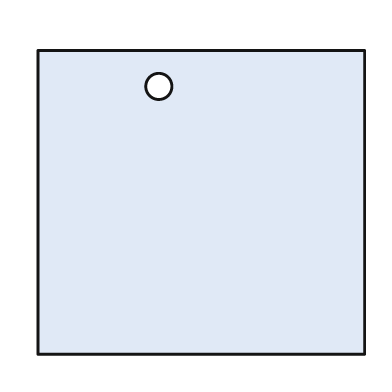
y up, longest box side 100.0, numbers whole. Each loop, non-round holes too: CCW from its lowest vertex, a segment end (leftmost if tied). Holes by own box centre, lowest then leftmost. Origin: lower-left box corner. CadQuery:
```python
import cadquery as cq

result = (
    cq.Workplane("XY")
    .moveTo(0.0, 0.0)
    .lineTo(100.0, 0.0)
    .lineTo(100.0, 93.0)
    .lineTo(0.0, 93.0)
    .close()
    .moveTo(37.0, 82.0)
    .circle(4.0)
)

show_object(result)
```